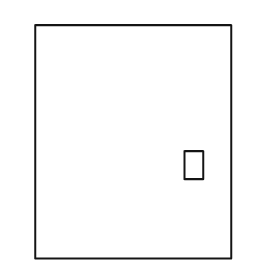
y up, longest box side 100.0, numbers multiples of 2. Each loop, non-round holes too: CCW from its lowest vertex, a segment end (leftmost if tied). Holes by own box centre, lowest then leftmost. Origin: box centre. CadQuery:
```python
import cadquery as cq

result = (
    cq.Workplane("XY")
    .moveTo(-42.0, -50.0)
    .lineTo(42.0, -50.0)
    .lineTo(42.0, 50.0)
    .lineTo(-42.0, 50.0)
    .close()
    .moveTo(22.0, -16.0)
    .lineTo(30.0, -16.0)
    .lineTo(30.0, -4.0)
    .lineTo(22.0, -4.0)
    .close()
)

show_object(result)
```